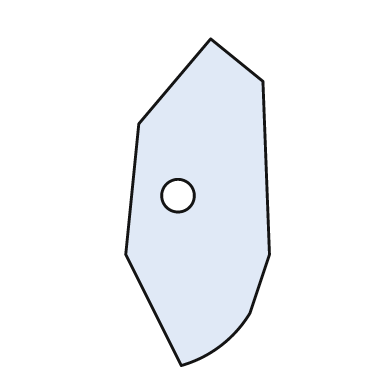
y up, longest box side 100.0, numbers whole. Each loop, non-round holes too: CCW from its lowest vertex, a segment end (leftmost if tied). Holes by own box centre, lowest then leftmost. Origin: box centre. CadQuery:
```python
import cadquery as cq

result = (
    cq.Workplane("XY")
    .moveTo(-5.0, -50.0)
    .threePointArc((7.0, -44.0), (16.0, -34.0))
    .lineTo(22.0, -16.0)
    .lineTo(20.0, 37.0)
    .lineTo(4.0, 50.0)
    .lineTo(-18.0, 24.0)
    .lineTo(-22.0, -16.0)
    .close()
    .moveTo(-6.0, 2.0)
    .circle(5.0)
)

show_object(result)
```